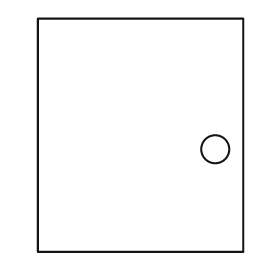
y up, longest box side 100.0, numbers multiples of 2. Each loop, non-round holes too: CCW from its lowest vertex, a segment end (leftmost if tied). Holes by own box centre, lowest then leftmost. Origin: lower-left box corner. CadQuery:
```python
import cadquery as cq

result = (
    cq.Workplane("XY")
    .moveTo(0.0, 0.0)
    .lineTo(88.0, 0.0)
    .lineTo(88.0, 100.0)
    .lineTo(0.0, 100.0)
    .close()
    .moveTo(76.0, 44.0)
    .circle(6.0)
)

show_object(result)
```